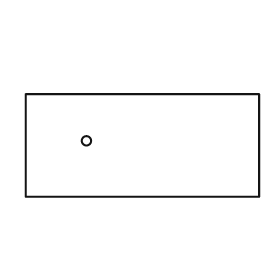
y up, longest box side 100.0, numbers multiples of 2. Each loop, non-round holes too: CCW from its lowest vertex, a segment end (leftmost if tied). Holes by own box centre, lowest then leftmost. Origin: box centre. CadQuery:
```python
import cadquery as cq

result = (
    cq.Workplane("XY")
    .moveTo(-50.0, -22.0)
    .lineTo(50.0, -22.0)
    .lineTo(50.0, 22.0)
    .lineTo(-50.0, 22.0)
    .close()
    .moveTo(-24.0, 2.0)
    .circle(2.0)
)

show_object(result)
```